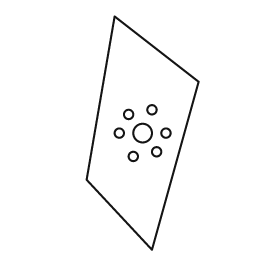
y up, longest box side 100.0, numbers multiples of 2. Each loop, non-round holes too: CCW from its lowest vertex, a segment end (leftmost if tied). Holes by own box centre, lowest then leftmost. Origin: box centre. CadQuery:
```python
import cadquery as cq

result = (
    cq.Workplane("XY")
    .moveTo(4.0, -50.0)
    .lineTo(24.0, 22.0)
    .lineTo(-12.0, 50.0)
    .lineTo(-24.0, -20.0)
    .close()
    .moveTo(-4.0, -10.0)
    .circle(2.0)
    .moveTo(6.0, -8.0)
    .circle(2.0)
    .moveTo(-10.0, 0.0)
    .circle(2.0)
    .moveTo(0.0, 0.0)
    .circle(4.0)
    .moveTo(10.0, 0.0)
    .circle(2.0)
    .moveTo(-6.0, 8.0)
    .circle(2.0)
    .moveTo(4.0, 10.0)
    .circle(2.0)
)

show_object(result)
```